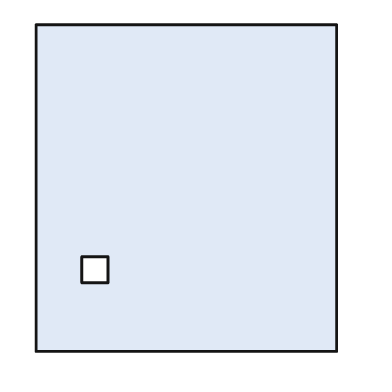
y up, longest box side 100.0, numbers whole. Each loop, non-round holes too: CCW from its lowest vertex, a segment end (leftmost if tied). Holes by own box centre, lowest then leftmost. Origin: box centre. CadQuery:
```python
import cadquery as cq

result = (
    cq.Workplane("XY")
    .moveTo(-46.0, -50.0)
    .lineTo(46.0, -50.0)
    .lineTo(46.0, 50.0)
    .lineTo(-46.0, 50.0)
    .close()
    .moveTo(-32.0, -29.0)
    .lineTo(-24.0, -29.0)
    .lineTo(-24.0, -21.0)
    .lineTo(-32.0, -21.0)
    .close()
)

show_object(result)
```